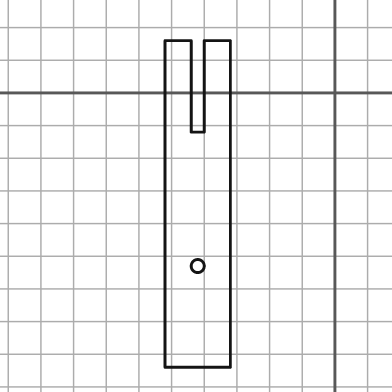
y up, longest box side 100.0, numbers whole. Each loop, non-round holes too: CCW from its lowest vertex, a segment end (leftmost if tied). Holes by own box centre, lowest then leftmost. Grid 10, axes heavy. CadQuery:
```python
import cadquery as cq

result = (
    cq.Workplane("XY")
    .moveTo(-52.0, -84.0)
    .lineTo(-32.0, -84.0)
    .lineTo(-32.0, 16.0)
    .lineTo(-40.0, 16.0)
    .lineTo(-40.0, -12.0)
    .lineTo(-44.0, -12.0)
    .lineTo(-44.0, 16.0)
    .lineTo(-52.0, 16.0)
    .close()
    .moveTo(-42.0, -53.0)
    .circle(2.0)
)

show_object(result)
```